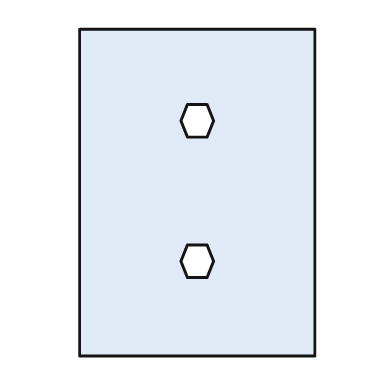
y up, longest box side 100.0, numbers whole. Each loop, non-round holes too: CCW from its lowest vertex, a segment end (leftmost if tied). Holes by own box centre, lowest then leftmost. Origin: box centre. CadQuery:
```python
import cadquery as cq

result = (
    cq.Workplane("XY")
    .moveTo(-36.0, -50.0)
    .lineTo(36.0, -50.0)
    .lineTo(36.0, 50.0)
    .lineTo(-36.0, 50.0)
    .close()
    .moveTo(-3.0, -26.0)
    .lineTo(3.0, -26.0)
    .lineTo(5.0, -21.0)
    .lineTo(3.0, -16.0)
    .lineTo(-3.0, -16.0)
    .lineTo(-5.0, -21.0)
    .close()
    .moveTo(-3.0, 17.0)
    .lineTo(3.0, 17.0)
    .lineTo(5.0, 22.0)
    .lineTo(3.0, 27.0)
    .lineTo(-3.0, 27.0)
    .lineTo(-5.0, 22.0)
    .close()
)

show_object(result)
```